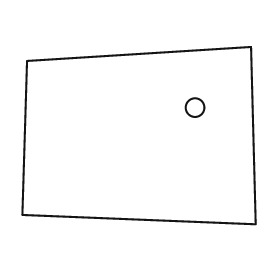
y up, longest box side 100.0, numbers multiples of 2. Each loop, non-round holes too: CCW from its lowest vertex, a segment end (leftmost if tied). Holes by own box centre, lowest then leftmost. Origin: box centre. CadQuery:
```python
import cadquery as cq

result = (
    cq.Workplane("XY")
    .moveTo(50.0, -38.0)
    .lineTo(48.0, 38.0)
    .lineTo(-48.0, 32.0)
    .lineTo(-50.0, -34.0)
    .close()
    .moveTo(24.0, 12.0)
    .circle(4.0)
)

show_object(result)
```